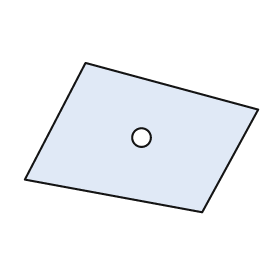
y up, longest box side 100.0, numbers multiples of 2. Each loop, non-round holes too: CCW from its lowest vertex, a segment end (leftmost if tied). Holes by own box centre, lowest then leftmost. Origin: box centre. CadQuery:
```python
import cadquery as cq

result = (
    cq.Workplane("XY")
    .moveTo(26.0, -32.0)
    .lineTo(50.0, 12.0)
    .lineTo(-24.0, 32.0)
    .lineTo(-50.0, -18.0)
    .close()
    .moveTo(0.0, 0.0)
    .circle(4.0)
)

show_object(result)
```